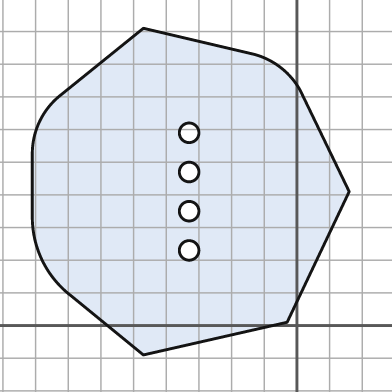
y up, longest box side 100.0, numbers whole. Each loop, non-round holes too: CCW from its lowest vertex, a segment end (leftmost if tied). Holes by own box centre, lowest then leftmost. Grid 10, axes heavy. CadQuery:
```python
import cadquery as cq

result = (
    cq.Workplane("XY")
    .moveTo(-47.0, -9.0)
    .lineTo(-3.0, 1.0)
    .lineTo(16.0, 41.0)
    .lineTo(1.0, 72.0)
    .threePointArc((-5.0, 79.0), (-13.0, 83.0))
    .lineTo(-47.0, 91.0)
    .lineTo(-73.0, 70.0)
    .threePointArc((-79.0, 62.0), (-81.0, 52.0))
    .lineTo(-81.0, 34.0)
    .threePointArc((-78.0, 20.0), (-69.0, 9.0))
    .close()
    .moveTo(-33.0, 23.0)
    .circle(3.0)
    .moveTo(-33.0, 35.0)
    .circle(3.0)
    .moveTo(-33.0, 47.0)
    .circle(3.0)
    .moveTo(-33.0, 59.0)
    .circle(3.0)
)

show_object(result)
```